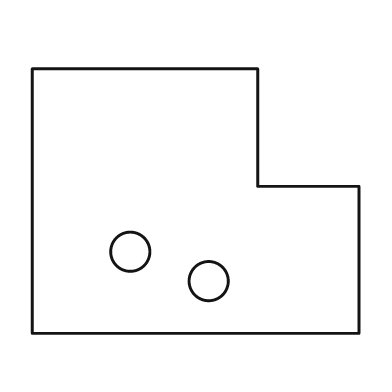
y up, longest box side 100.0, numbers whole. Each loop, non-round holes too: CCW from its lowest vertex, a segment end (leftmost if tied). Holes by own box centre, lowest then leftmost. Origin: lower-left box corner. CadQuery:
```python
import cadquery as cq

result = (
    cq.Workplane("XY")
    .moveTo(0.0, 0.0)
    .lineTo(100.0, 0.0)
    .lineTo(100.0, 45.0)
    .lineTo(69.0, 45.0)
    .lineTo(69.0, 81.0)
    .lineTo(0.0, 81.0)
    .close()
    .moveTo(54.0, 16.0)
    .circle(6.0)
    .moveTo(30.0, 25.0)
    .circle(6.0)
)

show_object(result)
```